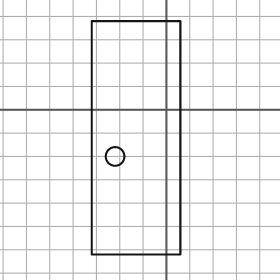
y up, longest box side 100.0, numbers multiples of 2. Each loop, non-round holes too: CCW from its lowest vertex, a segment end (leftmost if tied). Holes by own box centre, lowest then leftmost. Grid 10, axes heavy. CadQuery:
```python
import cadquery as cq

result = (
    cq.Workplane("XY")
    .moveTo(-32.0, -62.0)
    .lineTo(6.0, -62.0)
    .lineTo(6.0, 38.0)
    .lineTo(-32.0, 38.0)
    .close()
    .moveTo(-22.0, -20.0)
    .circle(4.0)
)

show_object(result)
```